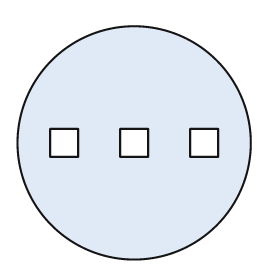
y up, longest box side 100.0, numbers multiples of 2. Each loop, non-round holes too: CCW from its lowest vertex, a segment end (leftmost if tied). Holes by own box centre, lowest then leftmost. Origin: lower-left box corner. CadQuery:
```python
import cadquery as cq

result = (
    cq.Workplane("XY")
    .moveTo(50.0, 50.0)
    .circle(50.0)
    .moveTo(14.0, 44.0)
    .lineTo(26.0, 44.0)
    .lineTo(26.0, 56.0)
    .lineTo(14.0, 56.0)
    .close()
    .moveTo(44.0, 44.0)
    .lineTo(56.0, 44.0)
    .lineTo(56.0, 56.0)
    .lineTo(44.0, 56.0)
    .close()
    .moveTo(74.0, 44.0)
    .lineTo(86.0, 44.0)
    .lineTo(86.0, 56.0)
    .lineTo(74.0, 56.0)
    .close()
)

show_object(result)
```